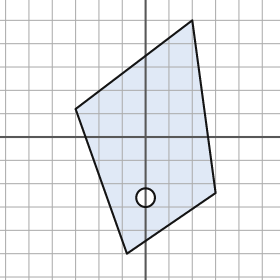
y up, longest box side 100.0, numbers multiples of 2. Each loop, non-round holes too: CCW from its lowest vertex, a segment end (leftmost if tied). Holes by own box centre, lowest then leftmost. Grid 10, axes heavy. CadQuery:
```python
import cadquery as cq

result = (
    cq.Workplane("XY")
    .moveTo(-8.0, -50.0)
    .lineTo(30.0, -24.0)
    .lineTo(20.0, 50.0)
    .lineTo(-30.0, 12.0)
    .close()
    .moveTo(0.0, -26.0)
    .circle(4.0)
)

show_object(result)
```